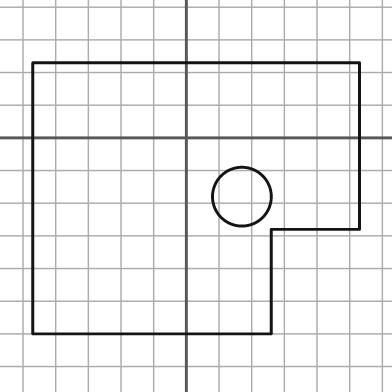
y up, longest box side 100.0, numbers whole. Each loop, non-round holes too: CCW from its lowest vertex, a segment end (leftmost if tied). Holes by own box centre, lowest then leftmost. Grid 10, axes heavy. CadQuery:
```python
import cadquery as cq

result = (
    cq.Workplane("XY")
    .moveTo(-47.0, -60.0)
    .lineTo(26.0, -60.0)
    .lineTo(26.0, -28.0)
    .lineTo(53.0, -28.0)
    .lineTo(53.0, 23.0)
    .lineTo(-47.0, 23.0)
    .close()
    .moveTo(17.0, -18.0)
    .circle(9.0)
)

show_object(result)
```